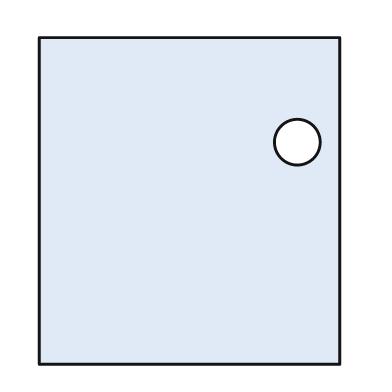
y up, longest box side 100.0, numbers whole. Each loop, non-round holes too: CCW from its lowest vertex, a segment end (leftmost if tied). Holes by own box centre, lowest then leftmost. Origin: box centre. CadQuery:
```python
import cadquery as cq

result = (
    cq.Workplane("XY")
    .moveTo(-46.0, -50.0)
    .lineTo(46.0, -50.0)
    .lineTo(46.0, 50.0)
    .lineTo(-46.0, 50.0)
    .close()
    .moveTo(33.0, 18.0)
    .circle(7.0)
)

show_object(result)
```